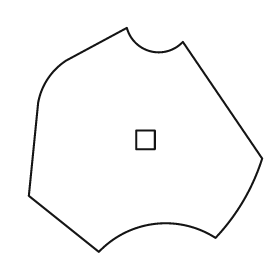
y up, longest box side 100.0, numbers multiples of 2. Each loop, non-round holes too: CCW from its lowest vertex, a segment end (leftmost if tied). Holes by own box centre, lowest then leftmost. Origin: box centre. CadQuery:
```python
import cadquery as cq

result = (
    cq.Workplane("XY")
    .moveTo(-20.0, -48.0)
    .threePointArc((4.0, -36.0), (30.0, -42.0))
    .threePointArc((42.0, -26.0), (50.0, -8.0))
    .lineTo(16.0, 42.0)
    .threePointArc((2.0, 38.0), (-8.0, 48.0))
    .lineTo(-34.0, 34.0)
    .threePointArc((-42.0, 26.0), (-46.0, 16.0))
    .lineTo(-50.0, -24.0)
    .close()
    .moveTo(-4.0, -4.0)
    .lineTo(4.0, -4.0)
    .lineTo(4.0, 4.0)
    .lineTo(-4.0, 4.0)
    .close()
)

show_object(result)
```